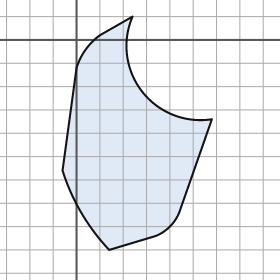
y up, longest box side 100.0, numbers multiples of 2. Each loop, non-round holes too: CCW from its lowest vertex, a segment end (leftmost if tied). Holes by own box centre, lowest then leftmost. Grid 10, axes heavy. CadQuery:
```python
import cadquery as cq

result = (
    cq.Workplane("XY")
    .moveTo(14.0, -90.0)
    .lineTo(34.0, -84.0)
    .threePointArc((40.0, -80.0), (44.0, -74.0))
    .lineTo(58.0, -34.0)
    .threePointArc((28.0, -22.0), (24.0, 10.0))
    .lineTo(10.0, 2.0)
    .threePointArc((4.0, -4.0), (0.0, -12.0))
    .lineTo(-6.0, -56.0)
    .threePointArc((2.0, -74.0), (14.0, -90.0))
    .close()
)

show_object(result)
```